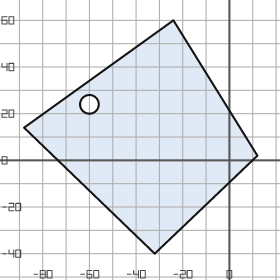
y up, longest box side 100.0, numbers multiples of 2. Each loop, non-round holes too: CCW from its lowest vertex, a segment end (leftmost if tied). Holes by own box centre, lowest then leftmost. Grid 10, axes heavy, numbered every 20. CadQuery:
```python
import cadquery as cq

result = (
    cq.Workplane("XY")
    .moveTo(-32.0, -40.0)
    .lineTo(12.0, 2.0)
    .lineTo(-24.0, 60.0)
    .lineTo(-88.0, 14.0)
    .close()
    .moveTo(-60.0, 24.0)
    .circle(4.0)
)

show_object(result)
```